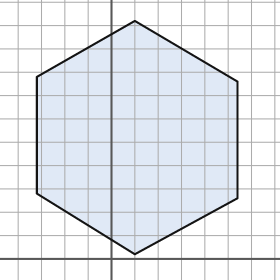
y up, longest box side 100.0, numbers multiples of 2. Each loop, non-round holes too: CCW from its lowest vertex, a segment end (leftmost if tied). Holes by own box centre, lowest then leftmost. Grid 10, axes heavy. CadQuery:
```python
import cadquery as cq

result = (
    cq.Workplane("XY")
    .moveTo(10.0, 2.0)
    .lineTo(54.0, 26.0)
    .lineTo(54.0, 76.0)
    .lineTo(10.0, 102.0)
    .lineTo(-32.0, 78.0)
    .lineTo(-32.0, 28.0)
    .close()
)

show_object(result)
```